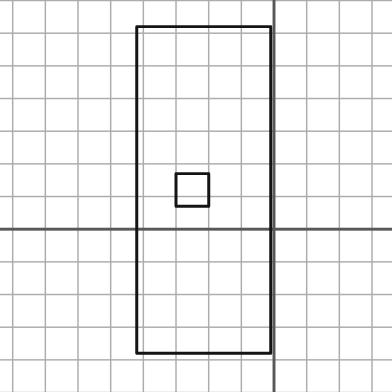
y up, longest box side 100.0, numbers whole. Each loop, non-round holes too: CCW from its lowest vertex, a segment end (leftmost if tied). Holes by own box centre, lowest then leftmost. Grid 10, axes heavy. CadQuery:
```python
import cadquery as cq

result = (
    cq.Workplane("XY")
    .moveTo(-42.0, -38.0)
    .lineTo(-1.0, -38.0)
    .lineTo(-1.0, 62.0)
    .lineTo(-42.0, 62.0)
    .close()
    .moveTo(-30.0, 7.0)
    .lineTo(-20.0, 7.0)
    .lineTo(-20.0, 17.0)
    .lineTo(-30.0, 17.0)
    .close()
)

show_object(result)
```